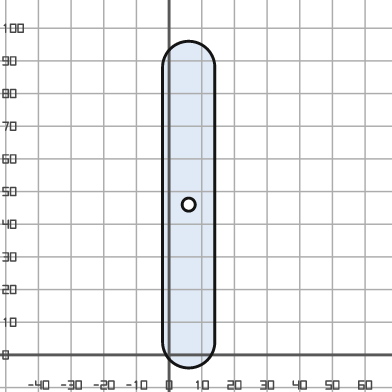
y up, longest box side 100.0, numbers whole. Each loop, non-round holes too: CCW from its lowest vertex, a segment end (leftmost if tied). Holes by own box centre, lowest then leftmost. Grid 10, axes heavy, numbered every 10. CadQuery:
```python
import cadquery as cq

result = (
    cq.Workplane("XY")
    .moveTo(-2.0, 4.0)
    .threePointArc((6.0, -4.0), (14.0, 4.0))
    .lineTo(14.0, 88.0)
    .threePointArc((6.0, 96.0), (-2.0, 88.0))
    .close()
    .moveTo(6.0, 46.0)
    .circle(2.0)
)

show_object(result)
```